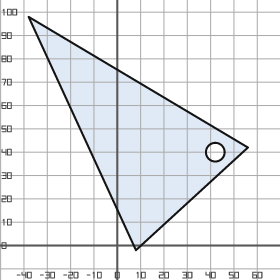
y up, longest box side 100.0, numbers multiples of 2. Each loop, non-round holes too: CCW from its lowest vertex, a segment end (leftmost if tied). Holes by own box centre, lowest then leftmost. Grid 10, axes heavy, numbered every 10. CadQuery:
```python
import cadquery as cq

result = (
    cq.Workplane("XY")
    .moveTo(8.0, -2.0)
    .lineTo(56.0, 42.0)
    .lineTo(-38.0, 98.0)
    .close()
    .moveTo(42.0, 40.0)
    .circle(4.0)
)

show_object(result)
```